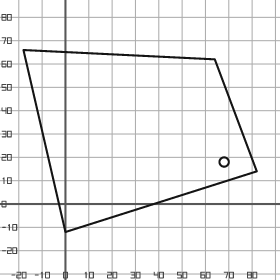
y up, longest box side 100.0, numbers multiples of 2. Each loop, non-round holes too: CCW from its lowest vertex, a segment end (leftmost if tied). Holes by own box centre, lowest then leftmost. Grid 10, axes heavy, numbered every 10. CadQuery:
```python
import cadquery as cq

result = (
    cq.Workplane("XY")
    .moveTo(0.0, -12.0)
    .lineTo(82.0, 14.0)
    .lineTo(64.0, 62.0)
    .lineTo(-18.0, 66.0)
    .close()
    .moveTo(68.0, 18.0)
    .circle(2.0)
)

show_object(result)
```